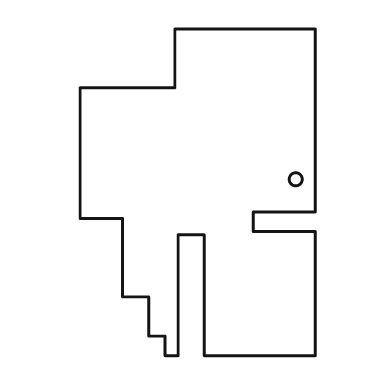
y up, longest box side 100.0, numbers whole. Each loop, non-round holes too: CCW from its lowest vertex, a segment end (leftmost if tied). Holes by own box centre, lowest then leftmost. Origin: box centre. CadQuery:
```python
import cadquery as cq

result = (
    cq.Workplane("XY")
    .moveTo(-10.0, -50.0)
    .lineTo(-6.0, -50.0)
    .lineTo(-6.0, -13.0)
    .lineTo(2.0, -13.0)
    .lineTo(2.0, -50.0)
    .lineTo(36.0, -50.0)
    .lineTo(36.0, -12.0)
    .lineTo(17.0, -12.0)
    .lineTo(17.0, -6.0)
    .lineTo(36.0, -6.0)
    .lineTo(36.0, 50.0)
    .lineTo(-7.0, 50.0)
    .lineTo(-7.0, 32.0)
    .lineTo(-36.0, 32.0)
    .lineTo(-36.0, -8.0)
    .lineTo(-23.0, -8.0)
    .lineTo(-23.0, -32.0)
    .lineTo(-15.0, -32.0)
    .lineTo(-15.0, -44.0)
    .lineTo(-10.0, -44.0)
    .close()
    .moveTo(30.0, 4.0)
    .circle(2.0)
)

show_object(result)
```